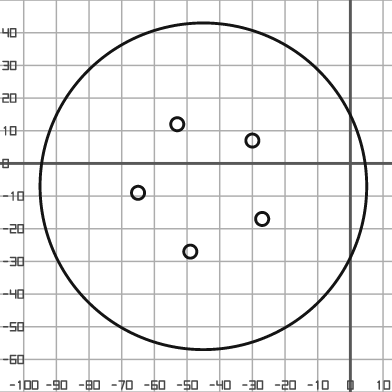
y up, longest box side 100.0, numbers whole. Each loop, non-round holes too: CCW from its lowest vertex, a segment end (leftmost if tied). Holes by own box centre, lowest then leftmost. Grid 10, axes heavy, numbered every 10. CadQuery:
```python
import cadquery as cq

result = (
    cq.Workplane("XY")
    .moveTo(-45.0, -7.0)
    .circle(50.0)
    .moveTo(-49.0, -27.0)
    .circle(2.0)
    .moveTo(-27.0, -17.0)
    .circle(2.0)
    .moveTo(-65.0, -9.0)
    .circle(2.0)
    .moveTo(-30.0, 7.0)
    .circle(2.0)
    .moveTo(-53.0, 12.0)
    .circle(2.0)
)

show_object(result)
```